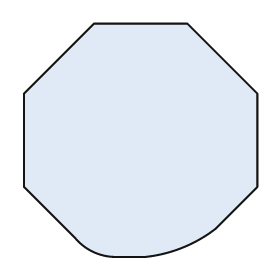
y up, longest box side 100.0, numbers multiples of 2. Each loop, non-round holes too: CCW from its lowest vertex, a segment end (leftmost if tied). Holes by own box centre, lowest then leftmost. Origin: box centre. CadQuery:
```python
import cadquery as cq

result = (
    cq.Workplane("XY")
    .moveTo(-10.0, -50.0)
    .lineTo(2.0, -50.0)
    .threePointArc((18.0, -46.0), (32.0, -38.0))
    .lineTo(50.0, -20.0)
    .lineTo(50.0, 20.0)
    .lineTo(20.0, 50.0)
    .lineTo(-20.0, 50.0)
    .lineTo(-50.0, 20.0)
    .lineTo(-50.0, -20.0)
    .lineTo(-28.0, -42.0)
    .threePointArc((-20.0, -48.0), (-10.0, -50.0))
    .close()
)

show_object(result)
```